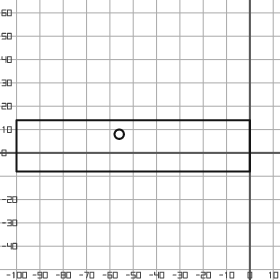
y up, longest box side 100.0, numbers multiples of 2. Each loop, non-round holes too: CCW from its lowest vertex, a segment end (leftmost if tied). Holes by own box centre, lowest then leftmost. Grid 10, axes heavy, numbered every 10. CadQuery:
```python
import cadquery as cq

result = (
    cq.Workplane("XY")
    .moveTo(-100.0, -8.0)
    .lineTo(0.0, -8.0)
    .lineTo(0.0, 14.0)
    .lineTo(-100.0, 14.0)
    .close()
    .moveTo(-56.0, 8.0)
    .circle(2.0)
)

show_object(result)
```